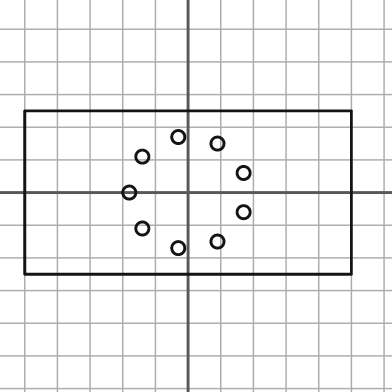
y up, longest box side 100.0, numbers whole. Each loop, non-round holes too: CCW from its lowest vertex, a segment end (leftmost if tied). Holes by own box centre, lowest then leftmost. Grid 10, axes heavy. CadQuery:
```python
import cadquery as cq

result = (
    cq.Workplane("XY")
    .moveTo(-50.0, -25.0)
    .lineTo(50.0, -25.0)
    .lineTo(50.0, 25.0)
    .lineTo(-50.0, 25.0)
    .close()
    .moveTo(-3.0, -17.0)
    .circle(2.0)
    .moveTo(9.0, -15.0)
    .circle(2.0)
    .moveTo(-14.0, -11.0)
    .circle(2.0)
    .moveTo(17.0, -6.0)
    .circle(2.0)
    .moveTo(-18.0, 0.0)
    .circle(2.0)
    .moveTo(17.0, 6.0)
    .circle(2.0)
    .moveTo(-14.0, 11.0)
    .circle(2.0)
    .moveTo(9.0, 15.0)
    .circle(2.0)
    .moveTo(-3.0, 17.0)
    .circle(2.0)
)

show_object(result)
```